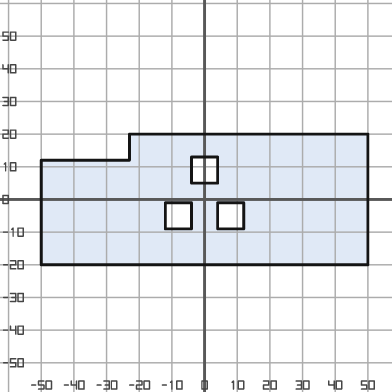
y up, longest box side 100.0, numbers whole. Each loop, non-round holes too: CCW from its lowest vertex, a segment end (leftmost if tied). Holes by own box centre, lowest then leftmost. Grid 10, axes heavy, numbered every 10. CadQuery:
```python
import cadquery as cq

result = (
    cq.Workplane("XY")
    .moveTo(-50.0, -20.0)
    .lineTo(50.0, -20.0)
    .lineTo(50.0, 20.0)
    .lineTo(-23.0, 20.0)
    .lineTo(-23.0, 12.0)
    .lineTo(-50.0, 12.0)
    .close()
    .moveTo(-12.0, -9.0)
    .lineTo(-4.0, -9.0)
    .lineTo(-4.0, -1.0)
    .lineTo(-12.0, -1.0)
    .close()
    .moveTo(4.0, -9.0)
    .lineTo(12.0, -9.0)
    .lineTo(12.0, -1.0)
    .lineTo(4.0, -1.0)
    .close()
    .moveTo(-4.0, 5.0)
    .lineTo(4.0, 5.0)
    .lineTo(4.0, 13.0)
    .lineTo(-4.0, 13.0)
    .close()
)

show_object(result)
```